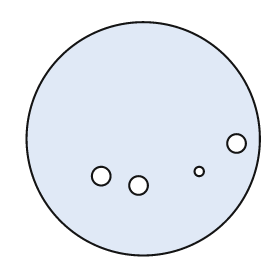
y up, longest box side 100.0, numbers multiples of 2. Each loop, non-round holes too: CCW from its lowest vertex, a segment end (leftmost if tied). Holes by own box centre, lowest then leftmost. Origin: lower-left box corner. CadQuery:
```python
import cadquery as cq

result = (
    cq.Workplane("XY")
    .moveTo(50.0, 50.0)
    .circle(50.0)
    .moveTo(48.0, 30.0)
    .circle(4.0)
    .moveTo(32.0, 34.0)
    .circle(4.0)
    .moveTo(74.0, 36.0)
    .circle(2.0)
    .moveTo(90.0, 48.0)
    .circle(4.0)
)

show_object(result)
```